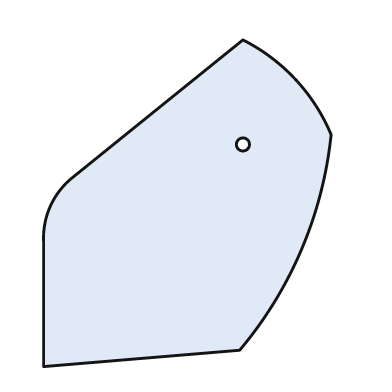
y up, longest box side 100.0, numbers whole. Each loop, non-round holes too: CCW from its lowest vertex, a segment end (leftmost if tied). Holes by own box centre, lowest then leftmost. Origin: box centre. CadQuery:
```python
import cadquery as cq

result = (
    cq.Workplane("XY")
    .moveTo(-44.0, -50.0)
    .lineTo(16.0, -45.0)
    .threePointArc((35.0, -14.0), (44.0, 21.0))
    .threePointArc((33.0, 38.0), (17.0, 50.0))
    .lineTo(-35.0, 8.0)
    .threePointArc((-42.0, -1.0), (-44.0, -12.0))
    .close()
    .moveTo(17.0, 18.0)
    .circle(2.0)
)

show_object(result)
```